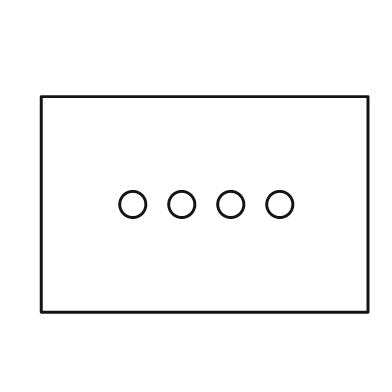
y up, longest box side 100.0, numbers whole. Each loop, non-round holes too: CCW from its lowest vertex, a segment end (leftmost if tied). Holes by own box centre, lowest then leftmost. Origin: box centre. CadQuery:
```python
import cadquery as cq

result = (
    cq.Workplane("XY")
    .moveTo(-50.0, -33.0)
    .lineTo(50.0, -33.0)
    .lineTo(50.0, 33.0)
    .lineTo(-50.0, 33.0)
    .close()
    .moveTo(-22.0, 0.0)
    .circle(4.0)
    .moveTo(-7.0, 0.0)
    .circle(4.0)
    .moveTo(8.0, 0.0)
    .circle(4.0)
    .moveTo(23.0, 0.0)
    .circle(4.0)
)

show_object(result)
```